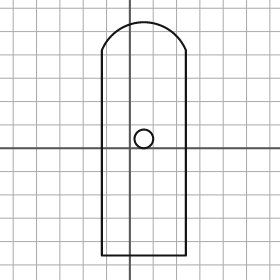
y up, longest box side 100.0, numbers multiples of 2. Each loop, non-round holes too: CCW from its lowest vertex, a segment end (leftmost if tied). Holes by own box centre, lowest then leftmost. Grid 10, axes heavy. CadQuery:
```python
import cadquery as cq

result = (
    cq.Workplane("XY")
    .moveTo(-12.0, -46.0)
    .lineTo(24.0, -46.0)
    .lineTo(24.0, 42.0)
    .threePointArc((6.0, 54.0), (-12.0, 42.0))
    .close()
    .moveTo(6.0, 4.0)
    .circle(4.0)
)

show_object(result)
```